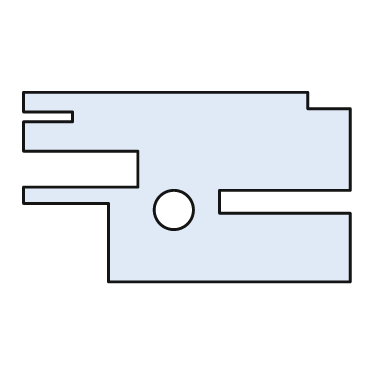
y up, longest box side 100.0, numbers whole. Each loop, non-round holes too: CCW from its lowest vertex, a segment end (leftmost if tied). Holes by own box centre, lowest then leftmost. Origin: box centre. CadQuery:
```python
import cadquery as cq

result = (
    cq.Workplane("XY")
    .moveTo(-24.0, -29.0)
    .lineTo(50.0, -29.0)
    .lineTo(50.0, -8.0)
    .lineTo(10.0, -8.0)
    .lineTo(10.0, -1.0)
    .lineTo(50.0, -1.0)
    .lineTo(50.0, 24.0)
    .lineTo(37.0, 24.0)
    .lineTo(37.0, 29.0)
    .lineTo(-50.0, 29.0)
    .lineTo(-50.0, 23.0)
    .lineTo(-35.0, 23.0)
    .lineTo(-35.0, 20.0)
    .lineTo(-50.0, 20.0)
    .lineTo(-50.0, 11.0)
    .lineTo(-15.0, 11.0)
    .lineTo(-15.0, 0.0)
    .lineTo(-50.0, 0.0)
    .lineTo(-50.0, -5.0)
    .lineTo(-24.0, -5.0)
    .close()
    .moveTo(-4.0, -7.0)
    .circle(6.0)
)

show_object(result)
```